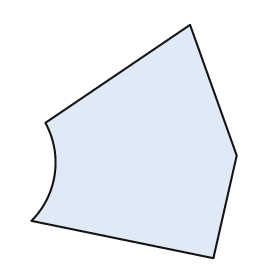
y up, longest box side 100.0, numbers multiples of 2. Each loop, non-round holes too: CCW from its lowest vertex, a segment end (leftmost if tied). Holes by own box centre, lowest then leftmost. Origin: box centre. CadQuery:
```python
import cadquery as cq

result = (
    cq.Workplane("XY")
    .moveTo(34.0, -50.0)
    .lineTo(44.0, -6.0)
    .lineTo(24.0, 50.0)
    .lineTo(-38.0, 8.0)
    .threePointArc((-34.0, -14.0), (-44.0, -34.0))
    .close()
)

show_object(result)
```